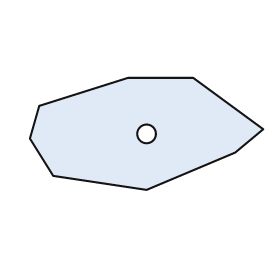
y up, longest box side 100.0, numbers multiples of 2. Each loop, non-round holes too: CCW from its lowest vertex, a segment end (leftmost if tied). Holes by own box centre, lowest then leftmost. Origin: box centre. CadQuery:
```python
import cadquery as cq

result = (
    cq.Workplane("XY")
    .moveTo(0.0, -24.0)
    .lineTo(38.0, -8.0)
    .lineTo(50.0, 2.0)
    .lineTo(20.0, 24.0)
    .lineTo(-8.0, 24.0)
    .lineTo(-46.0, 12.0)
    .lineTo(-50.0, -2.0)
    .lineTo(-40.0, -18.0)
    .close()
    .moveTo(0.0, 0.0)
    .circle(4.0)
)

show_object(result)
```